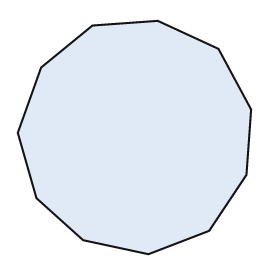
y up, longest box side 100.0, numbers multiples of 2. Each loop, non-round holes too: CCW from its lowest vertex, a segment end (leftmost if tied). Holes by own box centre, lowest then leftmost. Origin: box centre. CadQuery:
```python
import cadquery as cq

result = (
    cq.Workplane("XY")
    .moveTo(6.0, -50.0)
    .lineTo(32.0, -40.0)
    .lineTo(48.0, -16.0)
    .lineTo(50.0, 12.0)
    .lineTo(36.0, 38.0)
    .lineTo(10.0, 50.0)
    .lineTo(-18.0, 48.0)
    .lineTo(-40.0, 30.0)
    .lineTo(-50.0, 2.0)
    .lineTo(-42.0, -26.0)
    .lineTo(-22.0, -44.0)
    .close()
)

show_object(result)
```